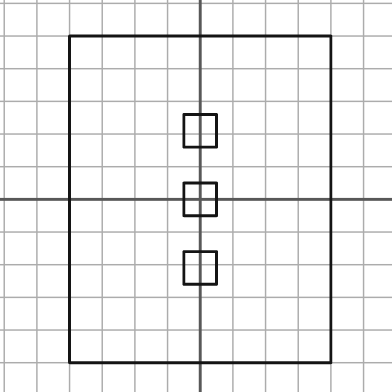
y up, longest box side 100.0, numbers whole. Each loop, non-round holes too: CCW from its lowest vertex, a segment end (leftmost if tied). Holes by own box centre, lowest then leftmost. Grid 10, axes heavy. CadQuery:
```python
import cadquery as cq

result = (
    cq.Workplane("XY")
    .moveTo(-40.0, -50.0)
    .lineTo(40.0, -50.0)
    .lineTo(40.0, 50.0)
    .lineTo(-40.0, 50.0)
    .close()
    .moveTo(-5.0, -26.0)
    .lineTo(5.0, -26.0)
    .lineTo(5.0, -16.0)
    .lineTo(-5.0, -16.0)
    .close()
    .moveTo(-5.0, -5.0)
    .lineTo(5.0, -5.0)
    .lineTo(5.0, 5.0)
    .lineTo(-5.0, 5.0)
    .close()
    .moveTo(-5.0, 16.0)
    .lineTo(5.0, 16.0)
    .lineTo(5.0, 26.0)
    .lineTo(-5.0, 26.0)
    .close()
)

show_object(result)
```